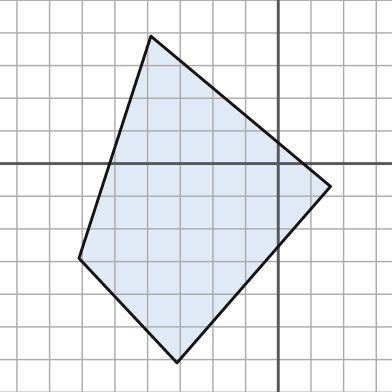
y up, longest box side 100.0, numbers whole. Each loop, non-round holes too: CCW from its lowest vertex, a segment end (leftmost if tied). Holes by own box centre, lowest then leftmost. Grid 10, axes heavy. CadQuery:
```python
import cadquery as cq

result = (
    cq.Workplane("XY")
    .moveTo(-31.0, -61.0)
    .lineTo(16.0, -7.0)
    .lineTo(-39.0, 39.0)
    .lineTo(-61.0, -29.0)
    .close()
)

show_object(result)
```